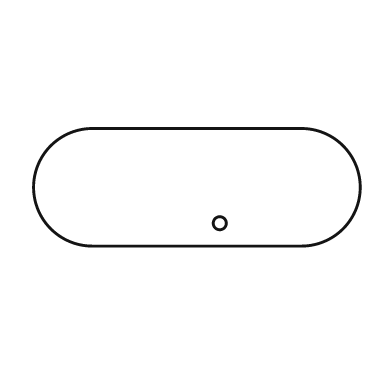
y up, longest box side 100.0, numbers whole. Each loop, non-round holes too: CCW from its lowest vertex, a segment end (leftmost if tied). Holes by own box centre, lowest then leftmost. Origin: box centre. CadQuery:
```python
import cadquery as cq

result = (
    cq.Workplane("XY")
    .moveTo(-32.0, -18.0)
    .lineTo(32.0, -18.0)
    .threePointArc((50.0, 0.0), (32.0, 18.0))
    .lineTo(-32.0, 18.0)
    .threePointArc((-50.0, 0.0), (-32.0, -18.0))
    .close()
    .moveTo(7.0, -11.0)
    .circle(2.0)
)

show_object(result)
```